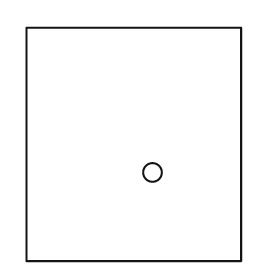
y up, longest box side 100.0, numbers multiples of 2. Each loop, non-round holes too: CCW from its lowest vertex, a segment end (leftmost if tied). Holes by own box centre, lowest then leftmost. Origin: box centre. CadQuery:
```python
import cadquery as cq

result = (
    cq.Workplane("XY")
    .moveTo(-46.0, -50.0)
    .lineTo(46.0, -50.0)
    .lineTo(46.0, 50.0)
    .lineTo(-46.0, 50.0)
    .close()
    .moveTo(8.0, -12.0)
    .circle(4.0)
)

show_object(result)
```